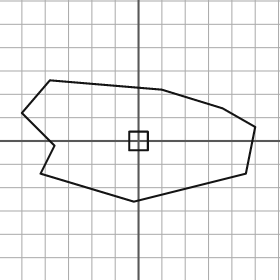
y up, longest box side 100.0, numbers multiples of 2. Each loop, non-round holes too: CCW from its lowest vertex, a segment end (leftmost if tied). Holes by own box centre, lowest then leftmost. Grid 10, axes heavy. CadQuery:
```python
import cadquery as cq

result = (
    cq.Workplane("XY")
    .moveTo(-2.0, -26.0)
    .lineTo(46.0, -14.0)
    .lineTo(50.0, 6.0)
    .lineTo(36.0, 14.0)
    .lineTo(10.0, 22.0)
    .lineTo(-38.0, 26.0)
    .lineTo(-50.0, 12.0)
    .lineTo(-36.0, -2.0)
    .lineTo(-42.0, -14.0)
    .close()
    .moveTo(-4.0, -4.0)
    .lineTo(4.0, -4.0)
    .lineTo(4.0, 4.0)
    .lineTo(-4.0, 4.0)
    .close()
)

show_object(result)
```